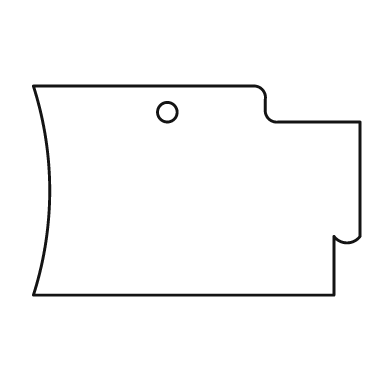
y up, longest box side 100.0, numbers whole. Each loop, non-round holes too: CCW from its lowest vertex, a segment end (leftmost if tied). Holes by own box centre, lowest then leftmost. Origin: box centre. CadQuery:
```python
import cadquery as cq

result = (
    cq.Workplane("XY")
    .moveTo(-50.0, -32.0)
    .lineTo(42.0, -32.0)
    .lineTo(42.0, -14.0)
    .threePointArc((46.0, -16.0), (50.0, -14.0))
    .lineTo(50.0, 21.0)
    .lineTo(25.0, 21.0)
    .threePointArc((22.0, 22.0), (21.0, 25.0))
    .lineTo(21.0, 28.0)
    .threePointArc((20.0, 31.0), (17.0, 32.0))
    .lineTo(-50.0, 32.0)
    .threePointArc((-45.0, 0.0), (-50.0, -32.0))
    .close()
    .moveTo(-9.0, 24.0)
    .circle(3.0)
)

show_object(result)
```